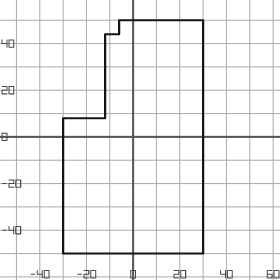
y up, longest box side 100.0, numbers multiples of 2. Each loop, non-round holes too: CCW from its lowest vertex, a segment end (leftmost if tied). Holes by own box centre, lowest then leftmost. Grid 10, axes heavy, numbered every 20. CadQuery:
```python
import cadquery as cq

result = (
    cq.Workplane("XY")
    .moveTo(-30.0, -50.0)
    .lineTo(30.0, -50.0)
    .lineTo(30.0, 50.0)
    .lineTo(-6.0, 50.0)
    .lineTo(-6.0, 44.0)
    .lineTo(-12.0, 44.0)
    .lineTo(-12.0, 8.0)
    .lineTo(-30.0, 8.0)
    .close()
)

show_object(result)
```